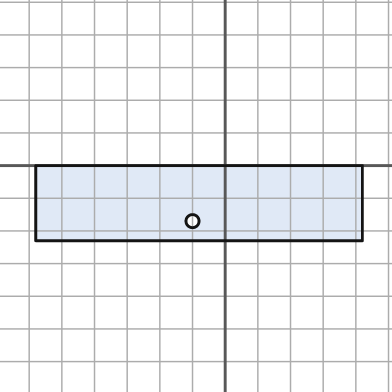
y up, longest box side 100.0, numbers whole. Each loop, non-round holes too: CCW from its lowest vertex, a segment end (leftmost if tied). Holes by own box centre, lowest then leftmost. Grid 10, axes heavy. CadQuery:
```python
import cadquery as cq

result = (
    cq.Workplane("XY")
    .moveTo(-58.0, -23.0)
    .lineTo(42.0, -23.0)
    .lineTo(42.0, 0.0)
    .lineTo(-58.0, 0.0)
    .close()
    .moveTo(-10.0, -17.0)
    .circle(2.0)
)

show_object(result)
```